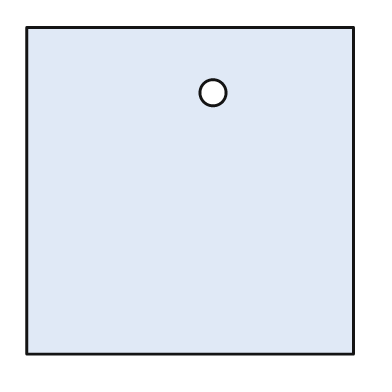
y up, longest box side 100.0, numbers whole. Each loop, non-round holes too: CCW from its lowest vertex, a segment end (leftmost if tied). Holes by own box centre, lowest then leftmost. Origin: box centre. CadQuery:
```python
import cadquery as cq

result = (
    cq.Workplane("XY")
    .moveTo(-50.0, -50.0)
    .lineTo(50.0, -50.0)
    .lineTo(50.0, 50.0)
    .lineTo(-50.0, 50.0)
    .close()
    .moveTo(7.0, 30.0)
    .circle(4.0)
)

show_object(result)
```